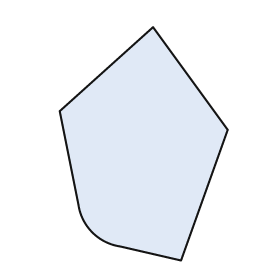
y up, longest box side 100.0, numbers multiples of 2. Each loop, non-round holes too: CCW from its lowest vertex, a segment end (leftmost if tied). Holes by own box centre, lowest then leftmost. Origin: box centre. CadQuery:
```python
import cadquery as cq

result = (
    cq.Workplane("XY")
    .moveTo(16.0, -50.0)
    .lineTo(36.0, 6.0)
    .lineTo(4.0, 50.0)
    .lineTo(-36.0, 14.0)
    .lineTo(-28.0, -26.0)
    .threePointArc((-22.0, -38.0), (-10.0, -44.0))
    .close()
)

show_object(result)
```